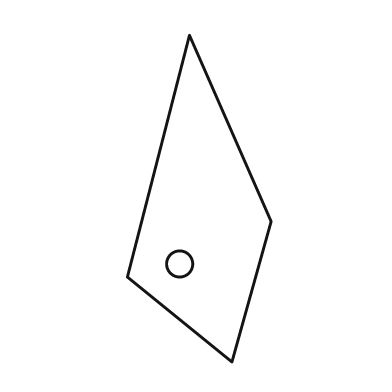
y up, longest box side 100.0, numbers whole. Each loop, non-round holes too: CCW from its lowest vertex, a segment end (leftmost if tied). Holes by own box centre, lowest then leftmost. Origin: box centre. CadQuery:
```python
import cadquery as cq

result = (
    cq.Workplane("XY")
    .moveTo(10.0, -50.0)
    .lineTo(22.0, -7.0)
    .lineTo(-3.0, 50.0)
    .lineTo(-22.0, -24.0)
    .close()
    .moveTo(-6.0, -20.0)
    .circle(4.0)
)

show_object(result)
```